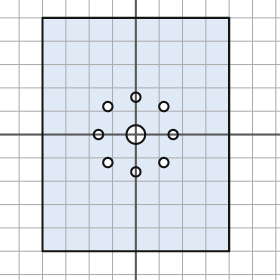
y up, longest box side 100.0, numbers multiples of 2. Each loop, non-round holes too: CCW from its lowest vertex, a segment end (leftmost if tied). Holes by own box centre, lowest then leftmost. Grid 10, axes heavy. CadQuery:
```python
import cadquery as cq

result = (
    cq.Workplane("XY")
    .moveTo(-40.0, -50.0)
    .lineTo(40.0, -50.0)
    .lineTo(40.0, 50.0)
    .lineTo(-40.0, 50.0)
    .close()
    .moveTo(0.0, -16.0)
    .circle(2.0)
    .moveTo(-12.0, -12.0)
    .circle(2.0)
    .moveTo(12.0, -12.0)
    .circle(2.0)
    .moveTo(-16.0, 0.0)
    .circle(2.0)
    .moveTo(0.0, 0.0)
    .circle(4.0)
    .moveTo(16.0, 0.0)
    .circle(2.0)
    .moveTo(-12.0, 12.0)
    .circle(2.0)
    .moveTo(12.0, 12.0)
    .circle(2.0)
    .moveTo(0.0, 16.0)
    .circle(2.0)
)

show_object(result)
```